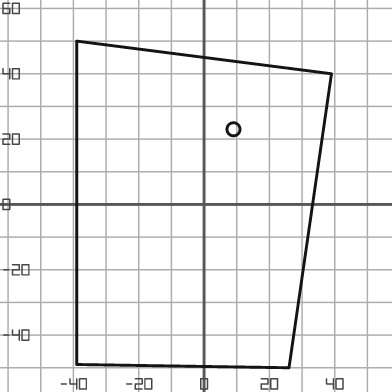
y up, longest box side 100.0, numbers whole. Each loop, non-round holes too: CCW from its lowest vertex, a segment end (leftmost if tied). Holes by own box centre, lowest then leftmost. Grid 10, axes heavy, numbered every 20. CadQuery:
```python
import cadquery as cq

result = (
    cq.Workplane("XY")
    .moveTo(26.0, -50.0)
    .lineTo(39.0, 40.0)
    .lineTo(-39.0, 50.0)
    .lineTo(-39.0, -49.0)
    .close()
    .moveTo(9.0, 23.0)
    .circle(2.0)
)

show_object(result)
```